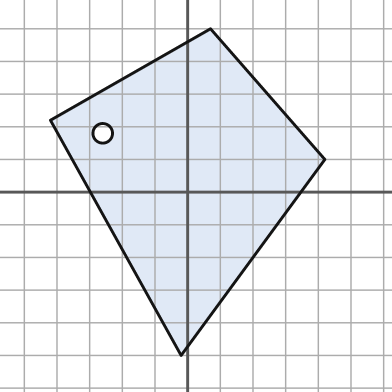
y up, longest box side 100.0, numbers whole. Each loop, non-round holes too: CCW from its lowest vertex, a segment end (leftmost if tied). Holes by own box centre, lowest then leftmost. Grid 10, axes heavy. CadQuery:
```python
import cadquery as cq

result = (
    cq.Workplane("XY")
    .moveTo(-2.0, -50.0)
    .lineTo(42.0, 10.0)
    .lineTo(7.0, 50.0)
    .lineTo(-42.0, 22.0)
    .close()
    .moveTo(-26.0, 18.0)
    .circle(3.0)
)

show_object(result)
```